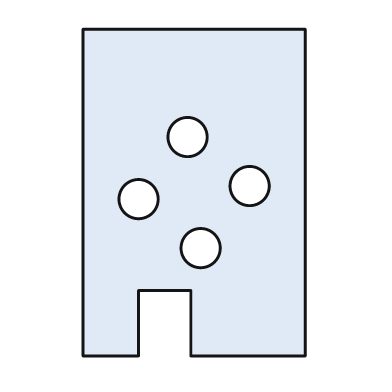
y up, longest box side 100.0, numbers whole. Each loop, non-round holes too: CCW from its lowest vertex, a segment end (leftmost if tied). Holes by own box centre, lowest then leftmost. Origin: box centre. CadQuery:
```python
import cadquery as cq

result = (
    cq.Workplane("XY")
    .moveTo(-34.0, -50.0)
    .lineTo(-17.0, -50.0)
    .lineTo(-17.0, -30.0)
    .lineTo(-1.0, -30.0)
    .lineTo(-1.0, -50.0)
    .lineTo(34.0, -50.0)
    .lineTo(34.0, 50.0)
    .lineTo(-34.0, 50.0)
    .close()
    .moveTo(2.0, -17.0)
    .circle(6.0)
    .moveTo(-17.0, -2.0)
    .circle(6.0)
    .moveTo(17.0, 2.0)
    .circle(6.0)
    .moveTo(-2.0, 17.0)
    .circle(6.0)
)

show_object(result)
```